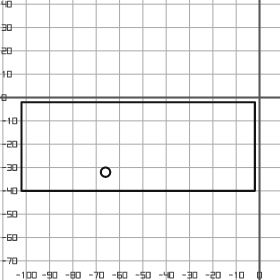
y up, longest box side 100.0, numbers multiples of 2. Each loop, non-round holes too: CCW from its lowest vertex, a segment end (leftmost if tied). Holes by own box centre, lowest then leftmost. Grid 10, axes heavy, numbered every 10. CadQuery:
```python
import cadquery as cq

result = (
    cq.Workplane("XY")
    .moveTo(-102.0, -40.0)
    .lineTo(-2.0, -40.0)
    .lineTo(-2.0, -2.0)
    .lineTo(-102.0, -2.0)
    .close()
    .moveTo(-66.0, -32.0)
    .circle(2.0)
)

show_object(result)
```